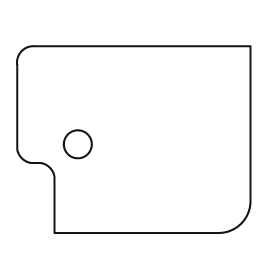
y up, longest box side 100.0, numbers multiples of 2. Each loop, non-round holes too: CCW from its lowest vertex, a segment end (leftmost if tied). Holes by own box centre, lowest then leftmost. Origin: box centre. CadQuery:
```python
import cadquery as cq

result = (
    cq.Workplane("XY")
    .moveTo(-34.0, -40.0)
    .lineTo(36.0, -40.0)
    .threePointArc((46.0, -36.0), (50.0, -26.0))
    .lineTo(50.0, 40.0)
    .lineTo(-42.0, 40.0)
    .threePointArc((-48.0, 38.0), (-50.0, 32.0))
    .lineTo(-50.0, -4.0)
    .threePointArc((-48.0, -8.0), (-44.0, -10.0))
    .lineTo(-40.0, -10.0)
    .threePointArc((-36.0, -12.0), (-34.0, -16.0))
    .close()
    .moveTo(-24.0, -2.0)
    .circle(6.0)
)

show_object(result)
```